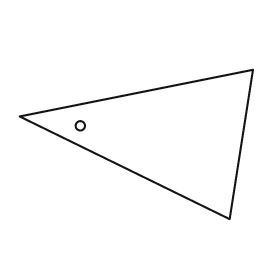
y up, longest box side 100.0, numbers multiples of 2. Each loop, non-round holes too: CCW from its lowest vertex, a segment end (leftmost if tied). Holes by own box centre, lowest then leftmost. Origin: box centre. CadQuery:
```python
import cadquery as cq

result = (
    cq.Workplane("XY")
    .moveTo(40.0, -32.0)
    .lineTo(50.0, 32.0)
    .lineTo(-50.0, 12.0)
    .close()
    .moveTo(-24.0, 8.0)
    .circle(2.0)
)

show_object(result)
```